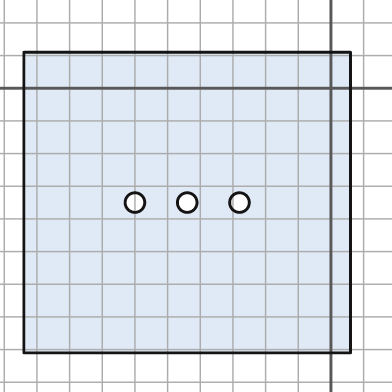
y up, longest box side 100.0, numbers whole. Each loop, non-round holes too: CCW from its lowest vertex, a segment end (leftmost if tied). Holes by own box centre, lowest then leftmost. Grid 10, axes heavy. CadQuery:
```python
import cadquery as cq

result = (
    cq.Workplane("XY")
    .moveTo(-94.0, -81.0)
    .lineTo(6.0, -81.0)
    .lineTo(6.0, 11.0)
    .lineTo(-94.0, 11.0)
    .close()
    .moveTo(-60.0, -35.0)
    .circle(3.0)
    .moveTo(-44.0, -35.0)
    .circle(3.0)
    .moveTo(-28.0, -35.0)
    .circle(3.0)
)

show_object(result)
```